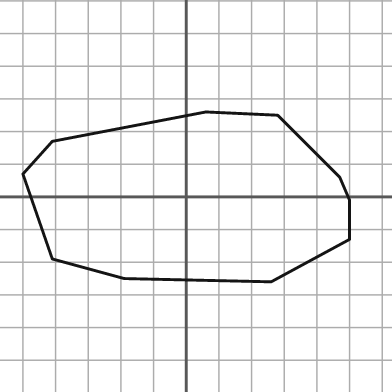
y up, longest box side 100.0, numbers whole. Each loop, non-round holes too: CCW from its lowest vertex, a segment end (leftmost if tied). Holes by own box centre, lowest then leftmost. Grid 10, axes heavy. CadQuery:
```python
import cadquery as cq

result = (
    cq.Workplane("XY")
    .moveTo(26.0, -26.0)
    .lineTo(50.0, -13.0)
    .lineTo(50.0, -1.0)
    .lineTo(47.0, 6.0)
    .lineTo(28.0, 25.0)
    .lineTo(6.0, 26.0)
    .lineTo(-41.0, 17.0)
    .lineTo(-50.0, 7.0)
    .lineTo(-41.0, -19.0)
    .lineTo(-19.0, -25.0)
    .close()
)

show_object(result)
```